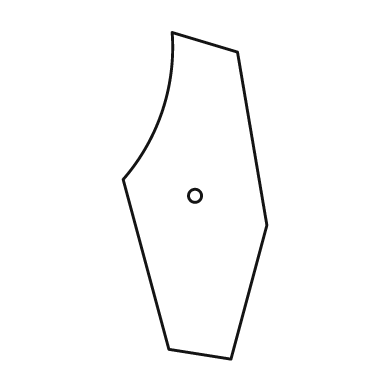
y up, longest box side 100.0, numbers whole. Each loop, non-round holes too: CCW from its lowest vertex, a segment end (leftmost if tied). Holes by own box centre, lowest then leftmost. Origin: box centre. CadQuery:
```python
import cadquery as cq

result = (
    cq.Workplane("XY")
    .moveTo(11.0, -50.0)
    .lineTo(22.0, -9.0)
    .lineTo(13.0, 44.0)
    .lineTo(-7.0, 50.0)
    .threePointArc((-10.0, 26.0), (-22.0, 5.0))
    .lineTo(-8.0, -47.0)
    .close()
    .moveTo(0.0, 0.0)
    .circle(2.0)
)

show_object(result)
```